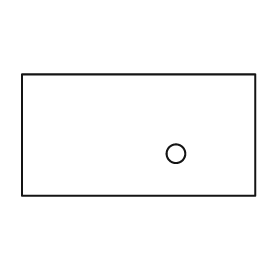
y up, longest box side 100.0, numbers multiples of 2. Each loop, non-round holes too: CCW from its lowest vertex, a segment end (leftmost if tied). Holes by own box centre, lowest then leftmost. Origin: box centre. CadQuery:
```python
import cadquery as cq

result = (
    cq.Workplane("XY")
    .moveTo(-50.0, -26.0)
    .lineTo(50.0, -26.0)
    .lineTo(50.0, 26.0)
    .lineTo(-50.0, 26.0)
    .close()
    .moveTo(16.0, -8.0)
    .circle(4.0)
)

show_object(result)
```